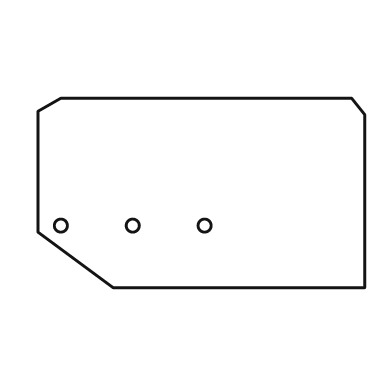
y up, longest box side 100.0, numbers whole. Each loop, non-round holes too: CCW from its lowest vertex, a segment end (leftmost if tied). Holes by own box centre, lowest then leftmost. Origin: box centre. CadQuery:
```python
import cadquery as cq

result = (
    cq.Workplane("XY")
    .moveTo(-27.0, -29.0)
    .lineTo(50.0, -29.0)
    .lineTo(50.0, 24.0)
    .lineTo(46.0, 29.0)
    .lineTo(-43.0, 29.0)
    .lineTo(-50.0, 25.0)
    .lineTo(-50.0, -12.0)
    .close()
    .moveTo(-43.0, -10.0)
    .circle(2.0)
    .moveTo(-21.0, -10.0)
    .circle(2.0)
    .moveTo(1.0, -10.0)
    .circle(2.0)
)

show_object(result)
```